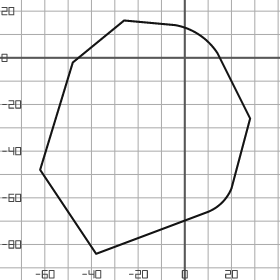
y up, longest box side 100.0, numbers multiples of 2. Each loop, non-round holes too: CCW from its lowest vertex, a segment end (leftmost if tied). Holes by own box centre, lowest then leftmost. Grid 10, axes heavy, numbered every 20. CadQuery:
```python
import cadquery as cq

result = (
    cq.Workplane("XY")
    .moveTo(-38.0, -84.0)
    .lineTo(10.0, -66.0)
    .threePointArc((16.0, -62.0), (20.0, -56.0))
    .lineTo(28.0, -26.0)
    .lineTo(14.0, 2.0)
    .threePointArc((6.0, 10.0), (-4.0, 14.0))
    .lineTo(-26.0, 16.0)
    .lineTo(-48.0, -2.0)
    .lineTo(-62.0, -48.0)
    .close()
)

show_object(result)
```